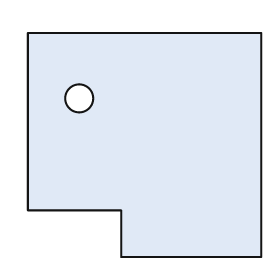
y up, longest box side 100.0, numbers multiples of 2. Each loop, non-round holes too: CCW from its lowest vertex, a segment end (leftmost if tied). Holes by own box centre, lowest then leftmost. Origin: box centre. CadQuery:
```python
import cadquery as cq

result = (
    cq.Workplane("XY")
    .moveTo(-10.0, -48.0)
    .lineTo(50.0, -48.0)
    .lineTo(50.0, 48.0)
    .lineTo(-50.0, 48.0)
    .lineTo(-50.0, -28.0)
    .lineTo(-10.0, -28.0)
    .close()
    .moveTo(-28.0, 20.0)
    .circle(6.0)
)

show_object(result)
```